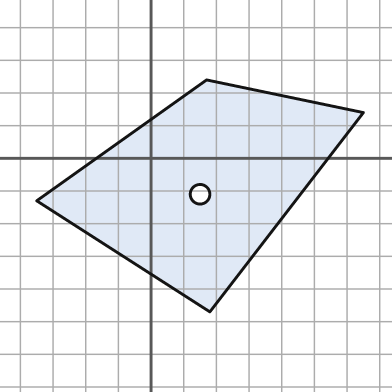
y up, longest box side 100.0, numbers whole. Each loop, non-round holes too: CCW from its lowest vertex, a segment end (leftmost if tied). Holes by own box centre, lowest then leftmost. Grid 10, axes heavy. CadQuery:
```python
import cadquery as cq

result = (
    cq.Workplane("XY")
    .moveTo(18.0, -47.0)
    .lineTo(65.0, 14.0)
    .lineTo(17.0, 24.0)
    .lineTo(-35.0, -13.0)
    .close()
    .moveTo(15.0, -11.0)
    .circle(3.0)
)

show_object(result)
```